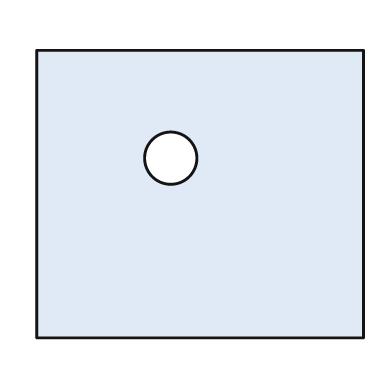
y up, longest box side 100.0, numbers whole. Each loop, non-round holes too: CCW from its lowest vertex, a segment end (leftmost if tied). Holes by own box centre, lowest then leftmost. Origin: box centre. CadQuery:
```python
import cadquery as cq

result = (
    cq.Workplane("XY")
    .moveTo(-50.0, -44.0)
    .lineTo(50.0, -44.0)
    .lineTo(50.0, 44.0)
    .lineTo(-50.0, 44.0)
    .close()
    .moveTo(-9.0, 11.0)
    .circle(8.0)
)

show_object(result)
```